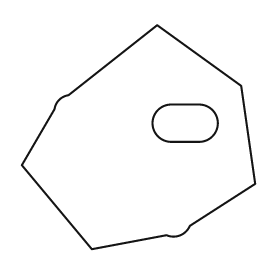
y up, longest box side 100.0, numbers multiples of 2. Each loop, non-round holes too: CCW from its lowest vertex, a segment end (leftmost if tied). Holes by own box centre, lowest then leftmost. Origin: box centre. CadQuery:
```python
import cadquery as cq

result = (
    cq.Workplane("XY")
    .moveTo(-20.0, -48.0)
    .lineTo(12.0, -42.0)
    .threePointArc((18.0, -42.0), (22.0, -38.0))
    .lineTo(50.0, -20.0)
    .lineTo(44.0, 22.0)
    .lineTo(8.0, 48.0)
    .lineTo(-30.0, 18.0)
    .threePointArc((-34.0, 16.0), (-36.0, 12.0))
    .lineTo(-50.0, -12.0)
    .close()
    .moveTo(14.0, -2.0)
    .lineTo(26.0, -2.0)
    .threePointArc((34.0, 6.0), (26.0, 14.0))
    .lineTo(14.0, 14.0)
    .threePointArc((6.0, 6.0), (14.0, -2.0))
    .close()
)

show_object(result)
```